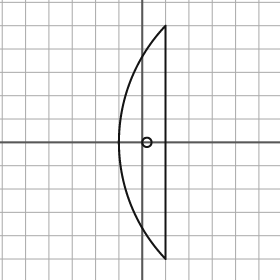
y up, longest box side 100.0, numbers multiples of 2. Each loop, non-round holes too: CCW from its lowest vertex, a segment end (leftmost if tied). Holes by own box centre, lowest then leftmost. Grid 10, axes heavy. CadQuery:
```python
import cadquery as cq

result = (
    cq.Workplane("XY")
    .moveTo(10.0, -50.0)
    .lineTo(10.0, 50.0)
    .threePointArc((-10.0, 0.0), (10.0, -50.0))
    .close()
    .moveTo(2.0, 0.0)
    .circle(2.0)
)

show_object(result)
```